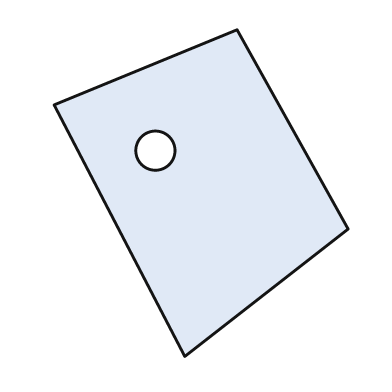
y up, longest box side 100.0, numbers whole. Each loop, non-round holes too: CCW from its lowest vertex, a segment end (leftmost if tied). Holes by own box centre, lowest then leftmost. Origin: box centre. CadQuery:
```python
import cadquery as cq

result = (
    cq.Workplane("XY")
    .moveTo(-5.0, -50.0)
    .lineTo(45.0, -11.0)
    .lineTo(11.0, 50.0)
    .lineTo(-45.0, 27.0)
    .close()
    .moveTo(-14.0, 13.0)
    .circle(6.0)
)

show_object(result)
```